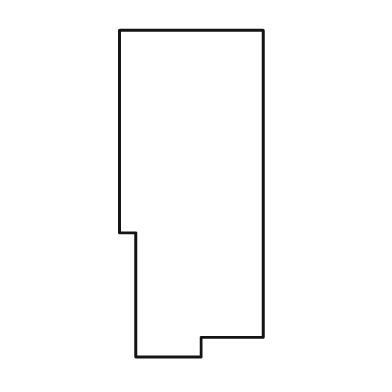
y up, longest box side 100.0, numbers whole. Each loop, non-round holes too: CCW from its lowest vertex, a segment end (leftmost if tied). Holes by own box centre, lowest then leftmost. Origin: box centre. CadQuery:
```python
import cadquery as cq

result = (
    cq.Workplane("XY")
    .moveTo(-17.0, -50.0)
    .lineTo(3.0, -50.0)
    .lineTo(3.0, -44.0)
    .lineTo(22.0, -44.0)
    .lineTo(22.0, 50.0)
    .lineTo(-22.0, 50.0)
    .lineTo(-22.0, -12.0)
    .lineTo(-17.0, -12.0)
    .close()
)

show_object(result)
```